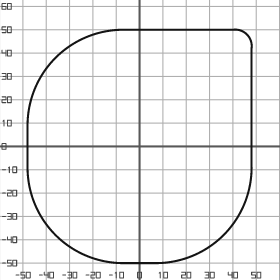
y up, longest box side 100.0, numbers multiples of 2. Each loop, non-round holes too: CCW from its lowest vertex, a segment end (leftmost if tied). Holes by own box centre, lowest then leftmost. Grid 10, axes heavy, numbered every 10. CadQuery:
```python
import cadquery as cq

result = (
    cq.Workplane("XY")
    .moveTo(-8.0, -50.0)
    .lineTo(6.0, -50.0)
    .threePointArc((36.0, -38.0), (48.0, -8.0))
    .lineTo(48.0, 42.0)
    .threePointArc((46.0, 48.0), (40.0, 50.0))
    .lineTo(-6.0, 50.0)
    .threePointArc((-36.0, 38.0), (-48.0, 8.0))
    .lineTo(-48.0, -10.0)
    .threePointArc((-36.0, -38.0), (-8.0, -50.0))
    .close()
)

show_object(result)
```